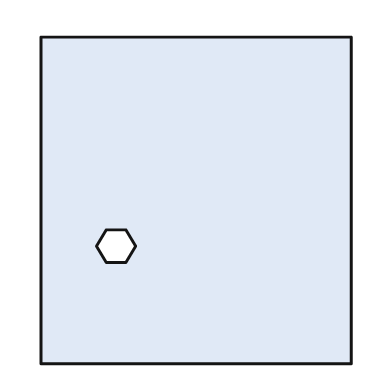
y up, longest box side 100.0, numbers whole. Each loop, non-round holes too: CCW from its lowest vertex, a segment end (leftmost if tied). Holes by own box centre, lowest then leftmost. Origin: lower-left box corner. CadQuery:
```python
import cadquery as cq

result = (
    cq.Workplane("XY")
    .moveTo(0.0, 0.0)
    .lineTo(95.0, 0.0)
    .lineTo(95.0, 100.0)
    .lineTo(0.0, 100.0)
    .close()
    .moveTo(20.0, 31.0)
    .lineTo(26.0, 31.0)
    .lineTo(29.0, 36.0)
    .lineTo(26.0, 41.0)
    .lineTo(20.0, 41.0)
    .lineTo(17.0, 36.0)
    .close()
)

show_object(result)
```